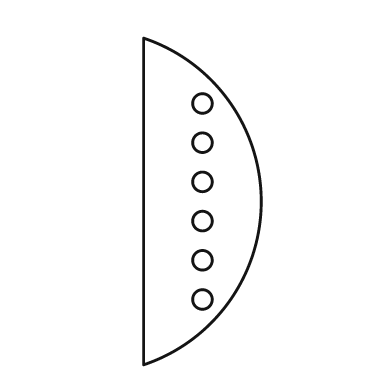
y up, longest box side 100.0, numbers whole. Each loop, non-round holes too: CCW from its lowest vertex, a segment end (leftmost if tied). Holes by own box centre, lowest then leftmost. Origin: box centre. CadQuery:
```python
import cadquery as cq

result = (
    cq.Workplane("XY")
    .moveTo(-18.0, -50.0)
    .threePointArc((18.0, 0.0), (-18.0, 50.0))
    .close()
    .moveTo(0.0, -30.0)
    .circle(3.0)
    .moveTo(0.0, -18.0)
    .circle(3.0)
    .moveTo(0.0, -6.0)
    .circle(3.0)
    .moveTo(0.0, 6.0)
    .circle(3.0)
    .moveTo(0.0, 18.0)
    .circle(3.0)
    .moveTo(0.0, 30.0)
    .circle(3.0)
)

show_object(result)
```